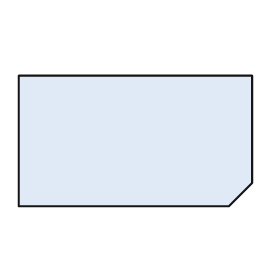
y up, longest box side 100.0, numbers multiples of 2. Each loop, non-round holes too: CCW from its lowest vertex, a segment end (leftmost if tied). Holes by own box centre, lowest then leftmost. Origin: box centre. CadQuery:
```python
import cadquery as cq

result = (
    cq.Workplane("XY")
    .moveTo(-50.0, -28.0)
    .lineTo(40.0, -28.0)
    .lineTo(50.0, -18.0)
    .lineTo(50.0, 28.0)
    .lineTo(-50.0, 28.0)
    .close()
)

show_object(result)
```